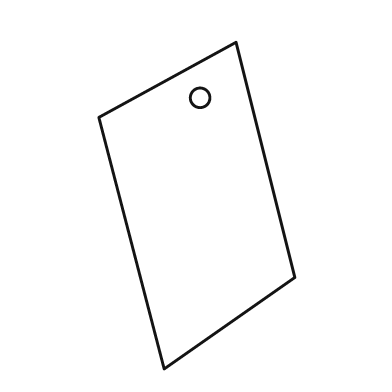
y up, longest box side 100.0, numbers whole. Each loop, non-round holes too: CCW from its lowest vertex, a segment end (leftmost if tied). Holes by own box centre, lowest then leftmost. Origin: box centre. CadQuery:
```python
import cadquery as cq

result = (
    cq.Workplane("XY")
    .moveTo(-10.0, -50.0)
    .lineTo(30.0, -22.0)
    .lineTo(12.0, 50.0)
    .lineTo(-30.0, 27.0)
    .close()
    .moveTo(1.0, 33.0)
    .circle(3.0)
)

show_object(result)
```